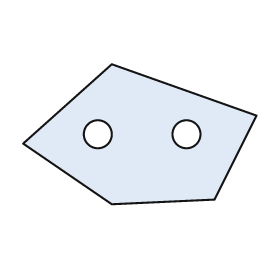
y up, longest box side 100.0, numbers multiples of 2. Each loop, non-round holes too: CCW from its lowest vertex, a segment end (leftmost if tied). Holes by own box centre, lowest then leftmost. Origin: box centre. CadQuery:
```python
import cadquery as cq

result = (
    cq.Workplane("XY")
    .moveTo(-12.0, -30.0)
    .lineTo(32.0, -28.0)
    .lineTo(50.0, 8.0)
    .lineTo(-12.0, 30.0)
    .lineTo(-50.0, -4.0)
    .close()
    .moveTo(-18.0, 0.0)
    .circle(6.0)
    .moveTo(20.0, 0.0)
    .circle(6.0)
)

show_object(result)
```